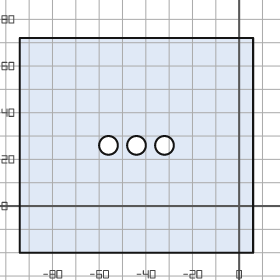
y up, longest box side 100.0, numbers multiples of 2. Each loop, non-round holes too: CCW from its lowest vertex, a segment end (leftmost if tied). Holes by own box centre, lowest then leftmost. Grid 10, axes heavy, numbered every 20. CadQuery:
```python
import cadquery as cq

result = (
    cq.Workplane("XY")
    .moveTo(-94.0, -20.0)
    .lineTo(6.0, -20.0)
    .lineTo(6.0, 72.0)
    .lineTo(-94.0, 72.0)
    .close()
    .moveTo(-56.0, 26.0)
    .circle(4.0)
    .moveTo(-44.0, 26.0)
    .circle(4.0)
    .moveTo(-32.0, 26.0)
    .circle(4.0)
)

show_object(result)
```